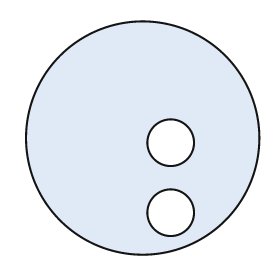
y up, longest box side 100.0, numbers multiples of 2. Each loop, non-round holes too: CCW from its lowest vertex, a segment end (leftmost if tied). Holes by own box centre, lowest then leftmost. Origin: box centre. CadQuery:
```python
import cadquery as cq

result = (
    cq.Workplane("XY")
    .moveTo(0.0, 0.0)
    .circle(50.0)
    .moveTo(12.0, -32.0)
    .circle(10.0)
    .moveTo(12.0, -2.0)
    .circle(10.0)
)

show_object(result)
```